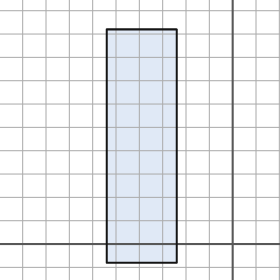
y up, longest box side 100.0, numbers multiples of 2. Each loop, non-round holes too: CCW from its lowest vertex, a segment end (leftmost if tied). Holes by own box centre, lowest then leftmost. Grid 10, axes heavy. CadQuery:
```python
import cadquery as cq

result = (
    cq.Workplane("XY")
    .moveTo(-54.0, -8.0)
    .lineTo(-24.0, -8.0)
    .lineTo(-24.0, 92.0)
    .lineTo(-54.0, 92.0)
    .close()
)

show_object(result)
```